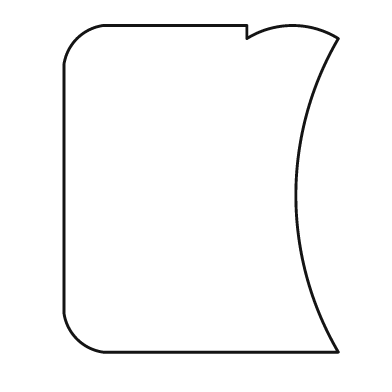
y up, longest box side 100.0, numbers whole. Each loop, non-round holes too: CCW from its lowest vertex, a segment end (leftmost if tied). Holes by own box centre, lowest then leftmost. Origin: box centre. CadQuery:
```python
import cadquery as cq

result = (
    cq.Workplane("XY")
    .moveTo(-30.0, -50.0)
    .lineTo(42.0, -50.0)
    .threePointArc((29.0, -2.0), (42.0, 46.0))
    .threePointArc((28.0, 50.0), (14.0, 46.0))
    .lineTo(14.0, 50.0)
    .lineTo(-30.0, 50.0)
    .threePointArc((-38.0, 46.0), (-42.0, 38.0))
    .lineTo(-42.0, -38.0)
    .threePointArc((-38.0, -46.0), (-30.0, -50.0))
    .close()
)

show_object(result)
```